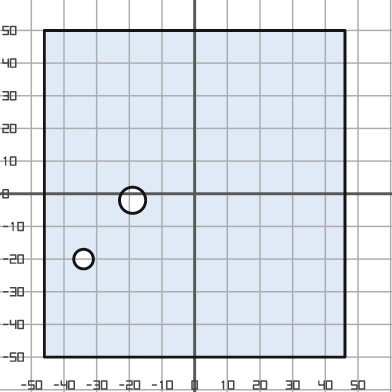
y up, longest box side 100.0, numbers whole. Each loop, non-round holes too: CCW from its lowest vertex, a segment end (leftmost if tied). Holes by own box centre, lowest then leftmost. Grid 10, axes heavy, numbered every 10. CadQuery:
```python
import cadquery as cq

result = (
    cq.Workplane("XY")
    .moveTo(-46.0, -50.0)
    .lineTo(46.0, -50.0)
    .lineTo(46.0, 50.0)
    .lineTo(-46.0, 50.0)
    .close()
    .moveTo(-34.0, -20.0)
    .circle(3.0)
    .moveTo(-19.0, -2.0)
    .circle(4.0)
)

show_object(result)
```